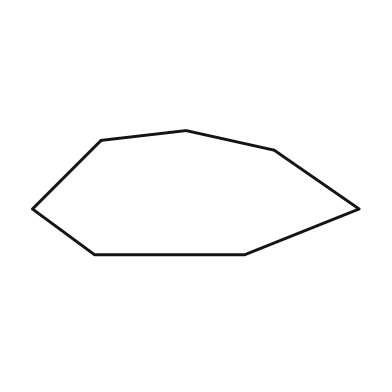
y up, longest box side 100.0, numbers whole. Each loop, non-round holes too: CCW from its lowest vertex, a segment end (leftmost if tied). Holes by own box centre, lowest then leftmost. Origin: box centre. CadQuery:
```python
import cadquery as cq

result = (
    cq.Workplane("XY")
    .moveTo(-31.0, -19.0)
    .lineTo(15.0, -19.0)
    .lineTo(50.0, -5.0)
    .lineTo(24.0, 13.0)
    .lineTo(-3.0, 19.0)
    .lineTo(-29.0, 16.0)
    .lineTo(-50.0, -5.0)
    .close()
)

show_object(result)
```